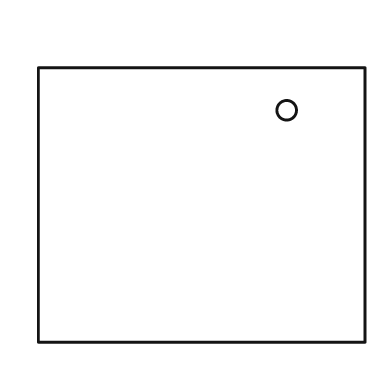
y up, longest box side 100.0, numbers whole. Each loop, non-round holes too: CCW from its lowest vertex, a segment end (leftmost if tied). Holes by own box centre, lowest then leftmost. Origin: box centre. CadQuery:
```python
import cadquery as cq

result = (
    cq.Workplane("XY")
    .moveTo(-50.0, -42.0)
    .lineTo(50.0, -42.0)
    .lineTo(50.0, 42.0)
    .lineTo(-50.0, 42.0)
    .close()
    .moveTo(26.0, 29.0)
    .circle(3.0)
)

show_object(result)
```